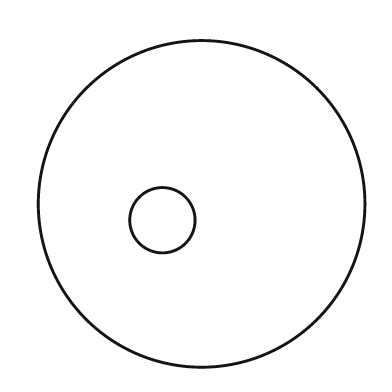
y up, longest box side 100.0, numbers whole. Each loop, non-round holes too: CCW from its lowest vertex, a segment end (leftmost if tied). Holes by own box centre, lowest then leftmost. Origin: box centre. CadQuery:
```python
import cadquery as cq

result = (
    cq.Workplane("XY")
    .moveTo(0.0, 0.0)
    .circle(50.0)
    .moveTo(-12.0, -5.0)
    .circle(10.0)
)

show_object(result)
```